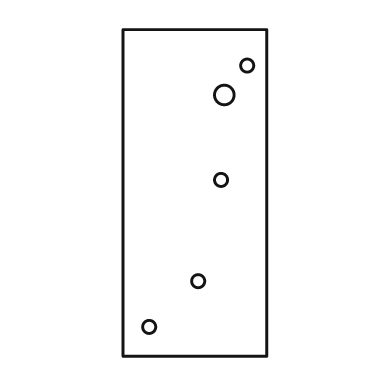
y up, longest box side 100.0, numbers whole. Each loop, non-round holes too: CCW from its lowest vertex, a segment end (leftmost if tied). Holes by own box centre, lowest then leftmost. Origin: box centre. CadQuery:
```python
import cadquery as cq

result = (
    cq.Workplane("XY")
    .moveTo(-22.0, -50.0)
    .lineTo(22.0, -50.0)
    .lineTo(22.0, 50.0)
    .lineTo(-22.0, 50.0)
    .close()
    .moveTo(-14.0, -41.0)
    .circle(2.0)
    .moveTo(1.0, -27.0)
    .circle(2.0)
    .moveTo(8.0, 4.0)
    .circle(2.0)
    .moveTo(9.0, 30.0)
    .circle(3.0)
    .moveTo(16.0, 39.0)
    .circle(2.0)
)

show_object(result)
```